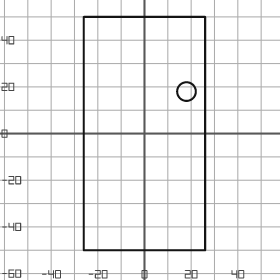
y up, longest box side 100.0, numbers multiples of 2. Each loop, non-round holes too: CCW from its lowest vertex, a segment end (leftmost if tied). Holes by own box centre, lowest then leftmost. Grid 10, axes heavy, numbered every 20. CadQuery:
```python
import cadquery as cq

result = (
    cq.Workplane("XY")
    .moveTo(-26.0, -50.0)
    .lineTo(26.0, -50.0)
    .lineTo(26.0, 50.0)
    .lineTo(-26.0, 50.0)
    .close()
    .moveTo(18.0, 18.0)
    .circle(4.0)
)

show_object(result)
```